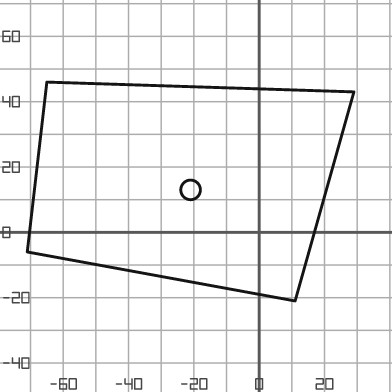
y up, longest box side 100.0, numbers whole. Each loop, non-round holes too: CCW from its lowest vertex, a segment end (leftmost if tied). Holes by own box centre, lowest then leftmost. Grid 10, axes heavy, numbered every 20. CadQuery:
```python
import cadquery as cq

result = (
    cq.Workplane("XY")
    .moveTo(11.0, -21.0)
    .lineTo(29.0, 43.0)
    .lineTo(-65.0, 46.0)
    .lineTo(-71.0, -6.0)
    .close()
    .moveTo(-21.0, 13.0)
    .circle(3.0)
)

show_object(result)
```